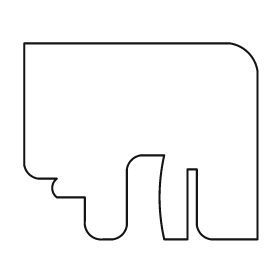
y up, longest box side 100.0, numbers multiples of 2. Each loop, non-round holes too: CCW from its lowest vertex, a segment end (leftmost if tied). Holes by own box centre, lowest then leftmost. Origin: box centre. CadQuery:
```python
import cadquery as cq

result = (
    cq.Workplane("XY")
    .moveTo(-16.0, -42.0)
    .lineTo(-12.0, -42.0)
    .threePointArc((-8.0, -40.0), (-6.0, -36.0))
    .lineTo(-6.0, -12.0)
    .threePointArc((-4.0, -8.0), (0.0, -6.0))
    .lineTo(10.0, -6.0)
    .threePointArc((8.0, -24.0), (10.0, -42.0))
    .lineTo(20.0, -42.0)
    .lineTo(20.0, -12.0)
    .lineTo(24.0, -12.0)
    .lineTo(24.0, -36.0)
    .threePointArc((26.0, -40.0), (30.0, -42.0))
    .lineTo(50.0, -42.0)
    .lineTo(50.0, 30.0)
    .threePointArc((46.0, 38.0), (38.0, 42.0))
    .lineTo(-50.0, 42.0)
    .lineTo(-50.0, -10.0)
    .threePointArc((-48.0, -14.0), (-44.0, -16.0))
    .lineTo(-36.0, -16.0)
    .threePointArc((-38.0, -20.0), (-36.0, -24.0))
    .lineTo(-24.0, -24.0)
    .lineTo(-24.0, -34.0)
    .threePointArc((-22.0, -40.0), (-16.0, -42.0))
    .close()
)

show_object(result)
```